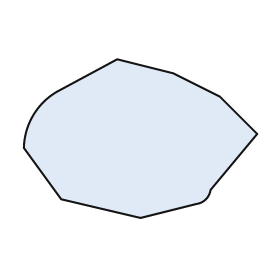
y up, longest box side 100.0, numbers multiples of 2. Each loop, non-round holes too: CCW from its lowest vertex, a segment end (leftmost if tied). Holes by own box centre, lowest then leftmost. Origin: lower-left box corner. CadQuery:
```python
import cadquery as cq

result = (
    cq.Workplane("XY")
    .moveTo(50.0, 0.0)
    .lineTo(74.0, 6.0)
    .threePointArc((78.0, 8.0), (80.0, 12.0))
    .lineTo(100.0, 36.0)
    .lineTo(84.0, 52.0)
    .lineTo(64.0, 62.0)
    .lineTo(40.0, 68.0)
    .lineTo(14.0, 54.0)
    .threePointArc((4.0, 44.0), (0.0, 30.0))
    .lineTo(16.0, 8.0)
    .close()
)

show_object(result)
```